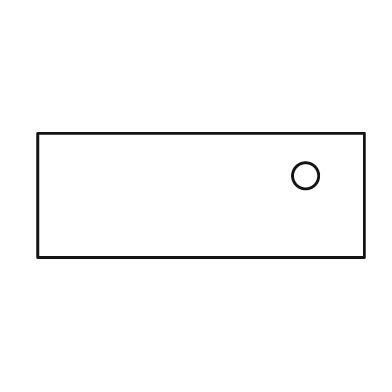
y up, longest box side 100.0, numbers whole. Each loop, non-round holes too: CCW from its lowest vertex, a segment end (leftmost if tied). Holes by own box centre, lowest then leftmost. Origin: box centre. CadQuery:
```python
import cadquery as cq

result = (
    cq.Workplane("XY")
    .moveTo(-50.0, -19.0)
    .lineTo(50.0, -19.0)
    .lineTo(50.0, 19.0)
    .lineTo(-50.0, 19.0)
    .close()
    .moveTo(32.0, 6.0)
    .circle(4.0)
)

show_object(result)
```